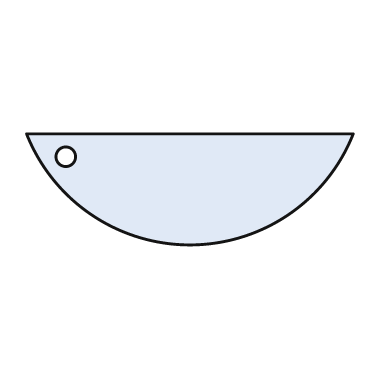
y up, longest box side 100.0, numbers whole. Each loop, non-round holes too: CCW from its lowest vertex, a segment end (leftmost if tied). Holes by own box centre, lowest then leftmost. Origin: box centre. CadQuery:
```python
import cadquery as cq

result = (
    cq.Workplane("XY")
    .moveTo(-50.0, 17.0)
    .threePointArc((0.0, -17.0), (50.0, 17.0))
    .close()
    .moveTo(-38.0, 10.0)
    .circle(3.0)
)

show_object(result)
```